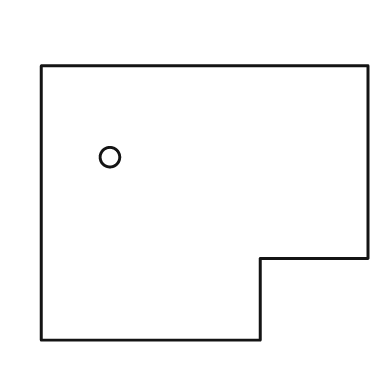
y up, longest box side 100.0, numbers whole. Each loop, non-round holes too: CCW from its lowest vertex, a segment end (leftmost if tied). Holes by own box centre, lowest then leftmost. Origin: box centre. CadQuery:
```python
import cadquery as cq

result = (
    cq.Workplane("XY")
    .moveTo(-50.0, -42.0)
    .lineTo(17.0, -42.0)
    .lineTo(17.0, -17.0)
    .lineTo(50.0, -17.0)
    .lineTo(50.0, 42.0)
    .lineTo(-50.0, 42.0)
    .close()
    .moveTo(-29.0, 14.0)
    .circle(3.0)
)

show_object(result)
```